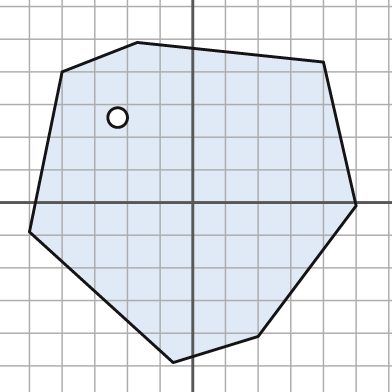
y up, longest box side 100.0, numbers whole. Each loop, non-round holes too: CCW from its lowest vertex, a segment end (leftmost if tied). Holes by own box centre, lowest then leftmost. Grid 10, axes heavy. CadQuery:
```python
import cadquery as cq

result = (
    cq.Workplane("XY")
    .moveTo(-6.0, -49.0)
    .lineTo(20.0, -41.0)
    .lineTo(50.0, -1.0)
    .lineTo(40.0, 43.0)
    .lineTo(-17.0, 49.0)
    .lineTo(-40.0, 40.0)
    .lineTo(-50.0, -9.0)
    .close()
    .moveTo(-23.0, 26.0)
    .circle(3.0)
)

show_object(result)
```